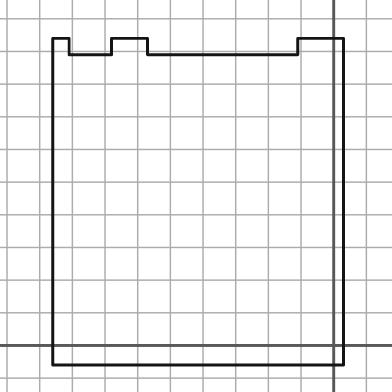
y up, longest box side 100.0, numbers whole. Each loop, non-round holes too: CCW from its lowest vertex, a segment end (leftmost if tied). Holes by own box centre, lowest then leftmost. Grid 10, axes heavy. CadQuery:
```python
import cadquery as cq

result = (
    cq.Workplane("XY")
    .moveTo(-86.0, -6.0)
    .lineTo(3.0, -6.0)
    .lineTo(3.0, 94.0)
    .lineTo(-11.0, 94.0)
    .lineTo(-11.0, 89.0)
    .lineTo(-57.0, 89.0)
    .lineTo(-57.0, 94.0)
    .lineTo(-68.0, 94.0)
    .lineTo(-68.0, 89.0)
    .lineTo(-81.0, 89.0)
    .lineTo(-81.0, 94.0)
    .lineTo(-86.0, 94.0)
    .close()
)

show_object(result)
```